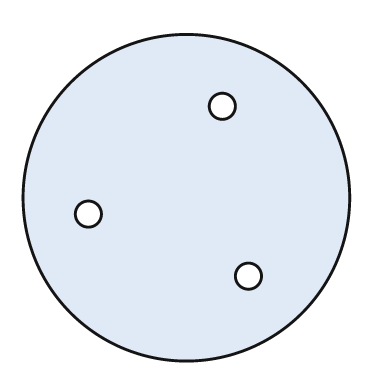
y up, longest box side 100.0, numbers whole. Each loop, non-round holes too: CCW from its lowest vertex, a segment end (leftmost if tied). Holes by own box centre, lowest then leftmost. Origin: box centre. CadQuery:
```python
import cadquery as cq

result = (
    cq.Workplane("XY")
    .moveTo(0.0, 0.0)
    .circle(50.0)
    .moveTo(19.0, -24.0)
    .circle(4.0)
    .moveTo(-30.0, -5.0)
    .circle(4.0)
    .moveTo(11.0, 28.0)
    .circle(4.0)
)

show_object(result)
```